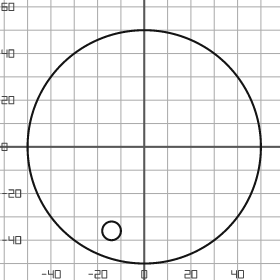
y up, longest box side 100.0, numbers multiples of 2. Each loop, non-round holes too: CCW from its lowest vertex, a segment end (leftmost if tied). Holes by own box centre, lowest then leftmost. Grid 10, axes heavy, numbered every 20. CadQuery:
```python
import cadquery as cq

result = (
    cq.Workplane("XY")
    .moveTo(0.0, 0.0)
    .circle(50.0)
    .moveTo(-14.0, -36.0)
    .circle(4.0)
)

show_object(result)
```